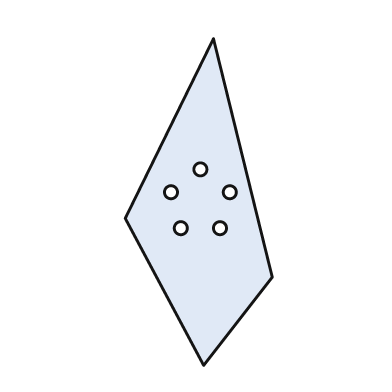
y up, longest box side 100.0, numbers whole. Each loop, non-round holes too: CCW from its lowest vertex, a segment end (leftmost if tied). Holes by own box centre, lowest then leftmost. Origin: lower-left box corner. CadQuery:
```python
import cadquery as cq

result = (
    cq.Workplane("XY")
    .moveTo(24.0, 0.0)
    .lineTo(45.0, 27.0)
    .lineTo(27.0, 100.0)
    .lineTo(0.0, 45.0)
    .close()
    .moveTo(17.0, 42.0)
    .circle(2.0)
    .moveTo(29.0, 42.0)
    .circle(2.0)
    .moveTo(14.0, 53.0)
    .circle(2.0)
    .moveTo(32.0, 53.0)
    .circle(2.0)
    .moveTo(23.0, 60.0)
    .circle(2.0)
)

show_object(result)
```